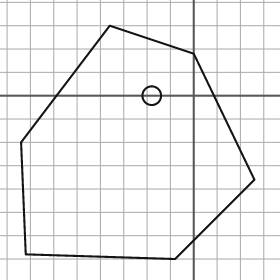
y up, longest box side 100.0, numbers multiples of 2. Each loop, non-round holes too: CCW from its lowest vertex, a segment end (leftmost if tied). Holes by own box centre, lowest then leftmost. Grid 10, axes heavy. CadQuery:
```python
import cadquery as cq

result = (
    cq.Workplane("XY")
    .moveTo(-8.0, -70.0)
    .lineTo(26.0, -36.0)
    .lineTo(0.0, 18.0)
    .lineTo(-36.0, 30.0)
    .lineTo(-74.0, -20.0)
    .lineTo(-72.0, -68.0)
    .close()
    .moveTo(-18.0, 0.0)
    .circle(4.0)
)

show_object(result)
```